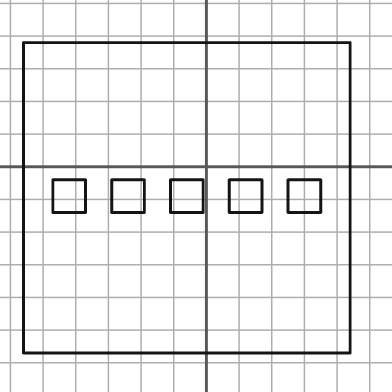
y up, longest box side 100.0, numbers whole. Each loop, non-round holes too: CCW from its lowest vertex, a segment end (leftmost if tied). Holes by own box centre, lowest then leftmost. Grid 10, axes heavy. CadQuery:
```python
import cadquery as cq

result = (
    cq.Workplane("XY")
    .moveTo(-56.0, -57.0)
    .lineTo(44.0, -57.0)
    .lineTo(44.0, 38.0)
    .lineTo(-56.0, 38.0)
    .close()
    .moveTo(-47.0, -14.0)
    .lineTo(-37.0, -14.0)
    .lineTo(-37.0, -4.0)
    .lineTo(-47.0, -4.0)
    .close()
    .moveTo(-29.0, -14.0)
    .lineTo(-19.0, -14.0)
    .lineTo(-19.0, -4.0)
    .lineTo(-29.0, -4.0)
    .close()
    .moveTo(-11.0, -14.0)
    .lineTo(-1.0, -14.0)
    .lineTo(-1.0, -4.0)
    .lineTo(-11.0, -4.0)
    .close()
    .moveTo(7.0, -14.0)
    .lineTo(17.0, -14.0)
    .lineTo(17.0, -4.0)
    .lineTo(7.0, -4.0)
    .close()
    .moveTo(25.0, -14.0)
    .lineTo(35.0, -14.0)
    .lineTo(35.0, -4.0)
    .lineTo(25.0, -4.0)
    .close()
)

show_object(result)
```